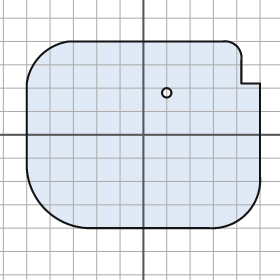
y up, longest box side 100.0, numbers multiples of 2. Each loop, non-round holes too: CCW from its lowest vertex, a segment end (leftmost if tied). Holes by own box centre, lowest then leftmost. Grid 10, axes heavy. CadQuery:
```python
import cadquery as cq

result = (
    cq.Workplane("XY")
    .moveTo(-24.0, -40.0)
    .lineTo(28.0, -40.0)
    .threePointArc((44.0, -34.0), (50.0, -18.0))
    .lineTo(50.0, 22.0)
    .lineTo(42.0, 22.0)
    .lineTo(42.0, 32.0)
    .threePointArc((40.0, 38.0), (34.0, 40.0))
    .lineTo(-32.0, 40.0)
    .threePointArc((-44.0, 34.0), (-50.0, 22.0))
    .lineTo(-50.0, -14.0)
    .threePointArc((-42.0, -32.0), (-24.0, -40.0))
    .close()
    .moveTo(10.0, 18.0)
    .circle(2.0)
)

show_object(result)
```